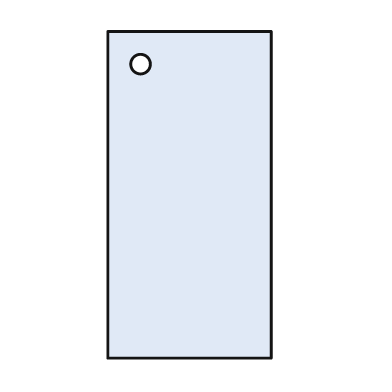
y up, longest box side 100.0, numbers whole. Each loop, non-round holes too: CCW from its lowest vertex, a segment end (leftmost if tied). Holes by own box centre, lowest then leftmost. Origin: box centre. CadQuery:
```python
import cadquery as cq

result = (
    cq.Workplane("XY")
    .moveTo(-25.0, -50.0)
    .lineTo(25.0, -50.0)
    .lineTo(25.0, 50.0)
    .lineTo(-25.0, 50.0)
    .close()
    .moveTo(-15.0, 40.0)
    .circle(3.0)
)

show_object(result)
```